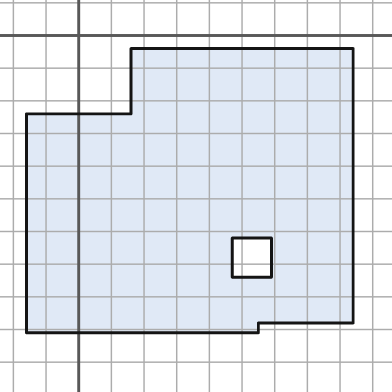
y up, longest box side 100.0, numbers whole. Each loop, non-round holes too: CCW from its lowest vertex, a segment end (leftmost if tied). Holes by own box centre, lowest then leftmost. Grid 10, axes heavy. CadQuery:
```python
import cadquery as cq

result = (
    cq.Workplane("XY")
    .moveTo(-16.0, -91.0)
    .lineTo(55.0, -91.0)
    .lineTo(55.0, -88.0)
    .lineTo(84.0, -88.0)
    .lineTo(84.0, -4.0)
    .lineTo(16.0, -4.0)
    .lineTo(16.0, -24.0)
    .lineTo(-16.0, -24.0)
    .close()
    .moveTo(47.0, -74.0)
    .lineTo(59.0, -74.0)
    .lineTo(59.0, -62.0)
    .lineTo(47.0, -62.0)
    .close()
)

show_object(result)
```